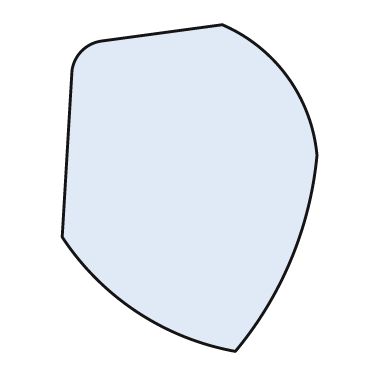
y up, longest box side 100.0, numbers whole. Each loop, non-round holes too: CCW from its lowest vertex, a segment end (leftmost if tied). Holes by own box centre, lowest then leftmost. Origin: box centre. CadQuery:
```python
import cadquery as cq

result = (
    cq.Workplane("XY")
    .moveTo(14.0, -50.0)
    .threePointArc((31.0, -22.0), (39.0, 10.0))
    .threePointArc((30.0, 34.0), (10.0, 50.0))
    .lineTo(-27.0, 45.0)
    .threePointArc((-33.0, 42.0), (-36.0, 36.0))
    .lineTo(-39.0, -15.0)
    .threePointArc((-16.0, -38.0), (14.0, -50.0))
    .close()
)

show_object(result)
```